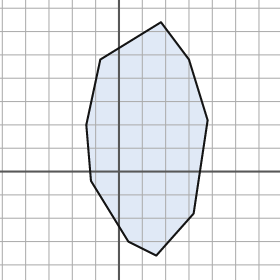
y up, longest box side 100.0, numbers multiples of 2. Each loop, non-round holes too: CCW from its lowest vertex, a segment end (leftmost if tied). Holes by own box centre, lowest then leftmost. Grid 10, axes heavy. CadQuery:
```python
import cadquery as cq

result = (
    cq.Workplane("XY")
    .moveTo(16.0, -36.0)
    .lineTo(32.0, -18.0)
    .lineTo(38.0, 22.0)
    .lineTo(30.0, 48.0)
    .lineTo(18.0, 64.0)
    .lineTo(-8.0, 48.0)
    .lineTo(-14.0, 20.0)
    .lineTo(-12.0, -4.0)
    .lineTo(4.0, -30.0)
    .close()
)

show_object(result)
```